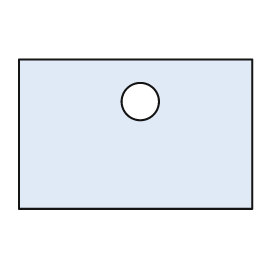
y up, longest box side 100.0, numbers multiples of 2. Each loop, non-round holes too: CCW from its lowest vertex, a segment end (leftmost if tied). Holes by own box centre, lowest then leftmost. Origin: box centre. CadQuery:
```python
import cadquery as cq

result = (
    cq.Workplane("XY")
    .moveTo(-50.0, -32.0)
    .lineTo(50.0, -32.0)
    .lineTo(50.0, 32.0)
    .lineTo(-50.0, 32.0)
    .close()
    .moveTo(2.0, 14.0)
    .circle(8.0)
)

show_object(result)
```